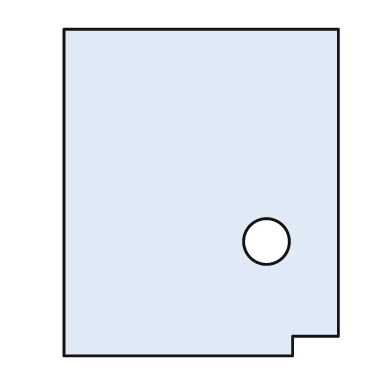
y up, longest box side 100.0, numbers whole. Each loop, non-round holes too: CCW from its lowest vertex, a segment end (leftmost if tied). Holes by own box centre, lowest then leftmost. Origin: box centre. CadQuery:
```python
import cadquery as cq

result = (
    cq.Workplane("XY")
    .moveTo(-42.0, -50.0)
    .lineTo(28.0, -50.0)
    .lineTo(28.0, -44.0)
    .lineTo(42.0, -44.0)
    .lineTo(42.0, 50.0)
    .lineTo(-42.0, 50.0)
    .close()
    .moveTo(20.0, -15.0)
    .circle(7.0)
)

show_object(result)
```